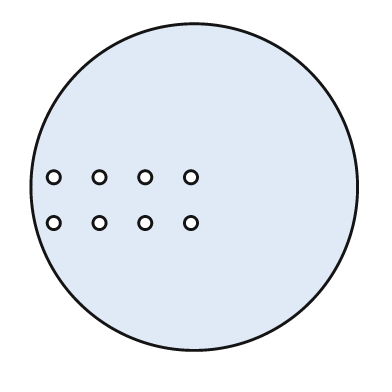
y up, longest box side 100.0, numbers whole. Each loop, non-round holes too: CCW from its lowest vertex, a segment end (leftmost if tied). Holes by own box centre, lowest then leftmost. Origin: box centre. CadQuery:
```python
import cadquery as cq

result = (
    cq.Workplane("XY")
    .moveTo(0.0, 0.0)
    .circle(50.0)
    .moveTo(-43.0, -11.0)
    .circle(2.0)
    .moveTo(-29.0, -11.0)
    .circle(2.0)
    .moveTo(-15.0, -11.0)
    .circle(2.0)
    .moveTo(-1.0, -11.0)
    .circle(2.0)
    .moveTo(-43.0, 3.0)
    .circle(2.0)
    .moveTo(-29.0, 3.0)
    .circle(2.0)
    .moveTo(-15.0, 3.0)
    .circle(2.0)
    .moveTo(-1.0, 3.0)
    .circle(2.0)
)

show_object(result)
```